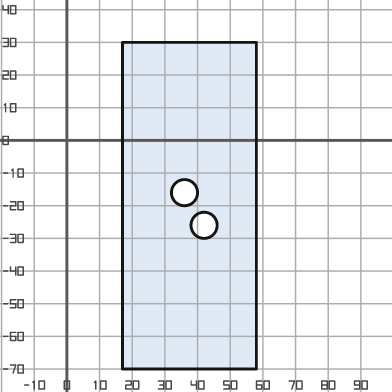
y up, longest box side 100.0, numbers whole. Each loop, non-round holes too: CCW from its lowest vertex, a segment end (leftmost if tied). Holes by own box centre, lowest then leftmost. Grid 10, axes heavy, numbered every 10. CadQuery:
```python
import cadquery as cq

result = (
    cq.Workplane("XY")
    .moveTo(17.0, -70.0)
    .lineTo(58.0, -70.0)
    .lineTo(58.0, 30.0)
    .lineTo(17.0, 30.0)
    .close()
    .moveTo(42.0, -26.0)
    .circle(4.0)
    .moveTo(36.0, -16.0)
    .circle(4.0)
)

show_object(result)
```